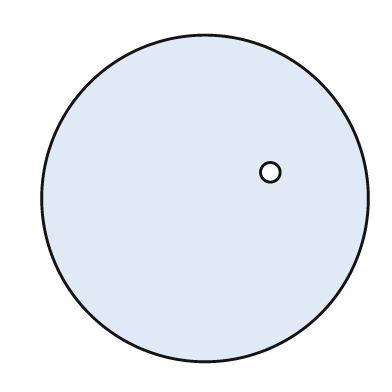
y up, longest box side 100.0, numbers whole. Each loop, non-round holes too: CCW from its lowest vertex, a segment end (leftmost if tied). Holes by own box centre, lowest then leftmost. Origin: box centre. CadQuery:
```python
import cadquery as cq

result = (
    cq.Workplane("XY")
    .moveTo(0.0, 0.0)
    .circle(50.0)
    .moveTo(20.0, 8.0)
    .circle(3.0)
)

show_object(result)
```